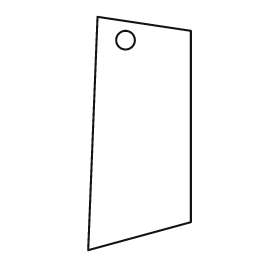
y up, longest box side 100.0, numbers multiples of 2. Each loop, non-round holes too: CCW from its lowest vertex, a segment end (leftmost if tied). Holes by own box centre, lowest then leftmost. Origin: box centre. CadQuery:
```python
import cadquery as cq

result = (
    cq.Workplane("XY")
    .moveTo(-22.0, -50.0)
    .lineTo(22.0, -38.0)
    .lineTo(22.0, 44.0)
    .lineTo(-18.0, 50.0)
    .close()
    .moveTo(-6.0, 40.0)
    .circle(4.0)
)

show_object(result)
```